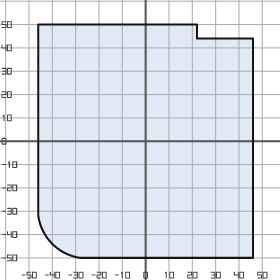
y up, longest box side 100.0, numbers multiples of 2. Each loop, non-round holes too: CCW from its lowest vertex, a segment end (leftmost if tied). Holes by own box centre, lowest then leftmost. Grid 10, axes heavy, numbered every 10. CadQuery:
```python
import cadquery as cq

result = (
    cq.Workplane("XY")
    .moveTo(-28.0, -50.0)
    .lineTo(46.0, -50.0)
    .lineTo(46.0, 44.0)
    .lineTo(22.0, 44.0)
    .lineTo(22.0, 50.0)
    .lineTo(-46.0, 50.0)
    .lineTo(-46.0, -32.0)
    .threePointArc((-40.0, -44.0), (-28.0, -50.0))
    .close()
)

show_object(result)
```